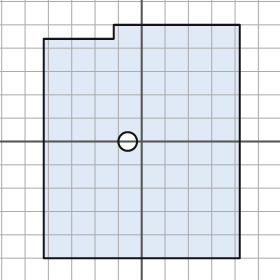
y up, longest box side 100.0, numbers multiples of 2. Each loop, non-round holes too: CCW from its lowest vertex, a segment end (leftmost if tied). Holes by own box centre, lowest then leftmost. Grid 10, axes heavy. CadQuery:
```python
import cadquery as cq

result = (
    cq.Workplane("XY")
    .moveTo(-42.0, -50.0)
    .lineTo(42.0, -50.0)
    .lineTo(42.0, 50.0)
    .lineTo(-12.0, 50.0)
    .lineTo(-12.0, 44.0)
    .lineTo(-42.0, 44.0)
    .close()
    .moveTo(-6.0, 0.0)
    .circle(4.0)
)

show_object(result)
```